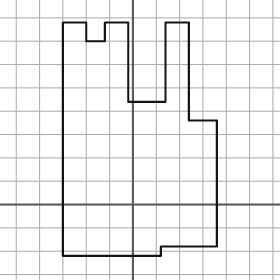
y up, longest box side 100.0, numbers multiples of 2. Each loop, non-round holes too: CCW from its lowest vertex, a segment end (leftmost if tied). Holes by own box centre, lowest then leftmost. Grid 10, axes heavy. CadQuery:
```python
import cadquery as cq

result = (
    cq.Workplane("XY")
    .moveTo(-30.0, -22.0)
    .lineTo(12.0, -22.0)
    .lineTo(12.0, -18.0)
    .lineTo(36.0, -18.0)
    .lineTo(36.0, 36.0)
    .lineTo(24.0, 36.0)
    .lineTo(24.0, 78.0)
    .lineTo(14.0, 78.0)
    .lineTo(14.0, 44.0)
    .lineTo(-2.0, 44.0)
    .lineTo(-2.0, 78.0)
    .lineTo(-12.0, 78.0)
    .lineTo(-12.0, 70.0)
    .lineTo(-20.0, 70.0)
    .lineTo(-20.0, 78.0)
    .lineTo(-30.0, 78.0)
    .close()
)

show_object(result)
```